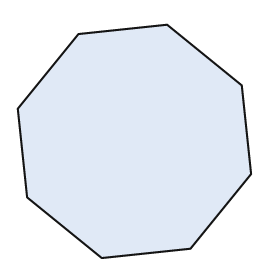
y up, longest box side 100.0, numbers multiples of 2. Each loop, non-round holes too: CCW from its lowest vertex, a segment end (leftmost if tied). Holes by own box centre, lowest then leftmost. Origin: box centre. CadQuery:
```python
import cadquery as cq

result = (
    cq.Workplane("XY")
    .moveTo(-14.0, -50.0)
    .lineTo(24.0, -46.0)
    .lineTo(50.0, -14.0)
    .lineTo(46.0, 24.0)
    .lineTo(14.0, 50.0)
    .lineTo(-24.0, 46.0)
    .lineTo(-50.0, 14.0)
    .lineTo(-46.0, -24.0)
    .close()
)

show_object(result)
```